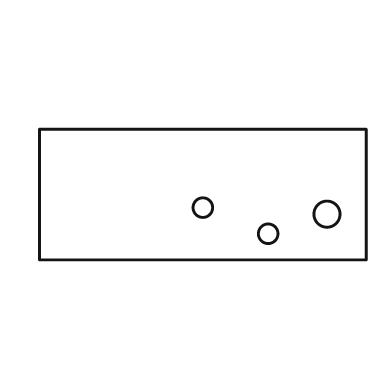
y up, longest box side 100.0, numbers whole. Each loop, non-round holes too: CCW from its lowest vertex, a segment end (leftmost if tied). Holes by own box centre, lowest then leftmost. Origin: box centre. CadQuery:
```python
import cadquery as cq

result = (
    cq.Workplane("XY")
    .moveTo(-50.0, -20.0)
    .lineTo(50.0, -20.0)
    .lineTo(50.0, 20.0)
    .lineTo(-50.0, 20.0)
    .close()
    .moveTo(20.0, -12.0)
    .circle(3.0)
    .moveTo(38.0, -6.0)
    .circle(4.0)
    .moveTo(0.0, -4.0)
    .circle(3.0)
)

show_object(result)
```